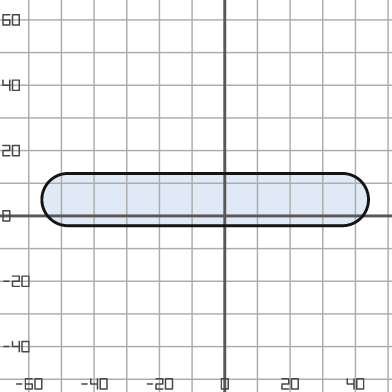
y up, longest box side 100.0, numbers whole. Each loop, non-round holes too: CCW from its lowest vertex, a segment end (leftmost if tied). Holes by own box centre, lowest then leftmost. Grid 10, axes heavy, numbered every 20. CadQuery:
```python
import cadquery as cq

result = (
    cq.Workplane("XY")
    .moveTo(-48.0, -3.0)
    .lineTo(36.0, -3.0)
    .threePointArc((44.0, 5.0), (36.0, 13.0))
    .lineTo(-48.0, 13.0)
    .threePointArc((-56.0, 5.0), (-48.0, -3.0))
    .close()
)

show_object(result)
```